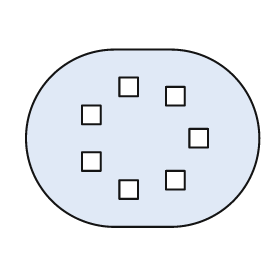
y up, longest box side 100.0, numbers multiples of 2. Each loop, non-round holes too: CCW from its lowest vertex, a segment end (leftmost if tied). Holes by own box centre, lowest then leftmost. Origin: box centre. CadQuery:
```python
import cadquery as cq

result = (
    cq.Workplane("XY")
    .moveTo(-12.0, -38.0)
    .lineTo(12.0, -38.0)
    .threePointArc((50.0, 0.0), (12.0, 38.0))
    .lineTo(-12.0, 38.0)
    .threePointArc((-50.0, 0.0), (-12.0, -38.0))
    .close()
    .moveTo(-10.0, -26.0)
    .lineTo(-2.0, -26.0)
    .lineTo(-2.0, -18.0)
    .lineTo(-10.0, -18.0)
    .close()
    .moveTo(10.0, -22.0)
    .lineTo(18.0, -22.0)
    .lineTo(18.0, -14.0)
    .lineTo(10.0, -14.0)
    .close()
    .moveTo(-26.0, -14.0)
    .lineTo(-18.0, -14.0)
    .lineTo(-18.0, -6.0)
    .lineTo(-26.0, -6.0)
    .close()
    .moveTo(20.0, -4.0)
    .lineTo(28.0, -4.0)
    .lineTo(28.0, 4.0)
    .lineTo(20.0, 4.0)
    .close()
    .moveTo(-26.0, 6.0)
    .lineTo(-18.0, 6.0)
    .lineTo(-18.0, 14.0)
    .lineTo(-26.0, 14.0)
    .close()
    .moveTo(10.0, 14.0)
    .lineTo(18.0, 14.0)
    .lineTo(18.0, 22.0)
    .lineTo(10.0, 22.0)
    .close()
    .moveTo(-10.0, 18.0)
    .lineTo(-2.0, 18.0)
    .lineTo(-2.0, 26.0)
    .lineTo(-10.0, 26.0)
    .close()
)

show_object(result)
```